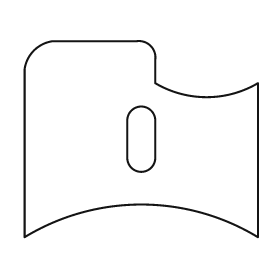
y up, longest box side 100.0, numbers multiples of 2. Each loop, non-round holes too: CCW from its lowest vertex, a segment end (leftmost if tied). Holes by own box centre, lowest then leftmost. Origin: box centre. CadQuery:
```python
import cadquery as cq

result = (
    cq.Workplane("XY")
    .moveTo(-50.0, -42.0)
    .threePointArc((0.0, -28.0), (50.0, -42.0))
    .lineTo(50.0, 24.0)
    .threePointArc((28.0, 18.0), (6.0, 24.0))
    .lineTo(6.0, 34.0)
    .threePointArc((4.0, 40.0), (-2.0, 42.0))
    .lineTo(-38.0, 42.0)
    .threePointArc((-46.0, 38.0), (-50.0, 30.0))
    .close()
    .moveTo(-6.0, -8.0)
    .threePointArc((0.0, -14.0), (6.0, -8.0))
    .lineTo(6.0, 8.0)
    .threePointArc((0.0, 14.0), (-6.0, 8.0))
    .close()
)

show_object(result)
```